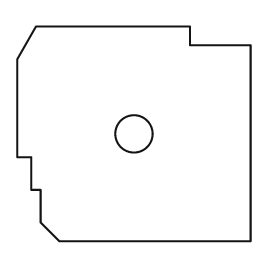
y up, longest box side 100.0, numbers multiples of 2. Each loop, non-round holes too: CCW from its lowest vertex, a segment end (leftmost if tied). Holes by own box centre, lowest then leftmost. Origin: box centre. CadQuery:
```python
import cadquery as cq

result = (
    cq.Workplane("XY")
    .moveTo(-32.0, -46.0)
    .lineTo(50.0, -46.0)
    .lineTo(50.0, 38.0)
    .lineTo(24.0, 38.0)
    .lineTo(24.0, 46.0)
    .lineTo(-42.0, 46.0)
    .lineTo(-50.0, 32.0)
    .lineTo(-50.0, -10.0)
    .lineTo(-44.0, -10.0)
    .lineTo(-44.0, -24.0)
    .lineTo(-40.0, -24.0)
    .lineTo(-40.0, -38.0)
    .close()
    .moveTo(0.0, 0.0)
    .circle(8.0)
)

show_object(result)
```